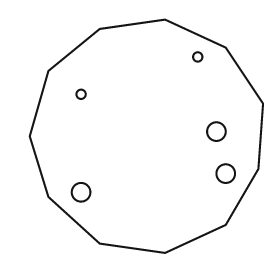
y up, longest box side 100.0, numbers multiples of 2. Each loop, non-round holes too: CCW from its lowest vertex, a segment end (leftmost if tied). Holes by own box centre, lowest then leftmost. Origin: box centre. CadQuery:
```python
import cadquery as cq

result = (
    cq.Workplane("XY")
    .moveTo(8.0, -50.0)
    .lineTo(34.0, -38.0)
    .lineTo(48.0, -14.0)
    .lineTo(50.0, 14.0)
    .lineTo(34.0, 38.0)
    .lineTo(8.0, 50.0)
    .lineTo(-20.0, 46.0)
    .lineTo(-42.0, 28.0)
    .lineTo(-50.0, 0.0)
    .lineTo(-42.0, -26.0)
    .lineTo(-20.0, -46.0)
    .close()
    .moveTo(-28.0, -24.0)
    .circle(4.0)
    .moveTo(34.0, -16.0)
    .circle(4.0)
    .moveTo(30.0, 2.0)
    .circle(4.0)
    .moveTo(-28.0, 18.0)
    .circle(2.0)
    .moveTo(22.0, 34.0)
    .circle(2.0)
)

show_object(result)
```